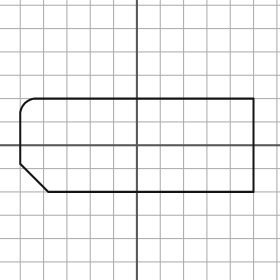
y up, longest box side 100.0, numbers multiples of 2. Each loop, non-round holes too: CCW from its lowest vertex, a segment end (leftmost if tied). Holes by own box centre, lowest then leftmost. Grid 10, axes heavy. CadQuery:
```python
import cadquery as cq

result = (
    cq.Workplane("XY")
    .moveTo(-38.0, -20.0)
    .lineTo(50.0, -20.0)
    .lineTo(50.0, 20.0)
    .lineTo(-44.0, 20.0)
    .threePointArc((-48.0, 18.0), (-50.0, 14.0))
    .lineTo(-50.0, -8.0)
    .close()
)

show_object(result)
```